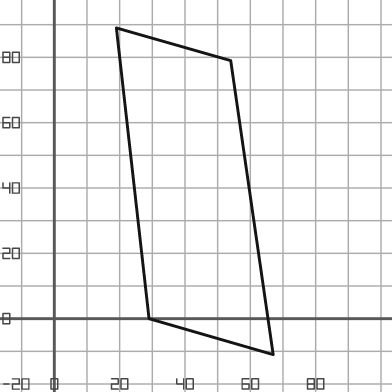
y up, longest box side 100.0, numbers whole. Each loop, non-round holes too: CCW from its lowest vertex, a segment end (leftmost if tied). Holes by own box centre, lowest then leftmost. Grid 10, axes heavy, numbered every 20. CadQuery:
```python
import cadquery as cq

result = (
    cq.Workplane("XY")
    .moveTo(67.0, -11.0)
    .lineTo(54.0, 79.0)
    .lineTo(19.0, 89.0)
    .lineTo(29.0, 0.0)
    .close()
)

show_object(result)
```